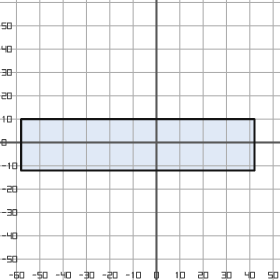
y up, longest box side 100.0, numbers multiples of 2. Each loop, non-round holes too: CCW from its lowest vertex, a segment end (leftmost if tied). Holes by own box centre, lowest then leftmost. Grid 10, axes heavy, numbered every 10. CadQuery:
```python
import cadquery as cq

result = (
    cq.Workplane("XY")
    .moveTo(-58.0, -12.0)
    .lineTo(42.0, -12.0)
    .lineTo(42.0, 10.0)
    .lineTo(-58.0, 10.0)
    .close()
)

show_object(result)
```